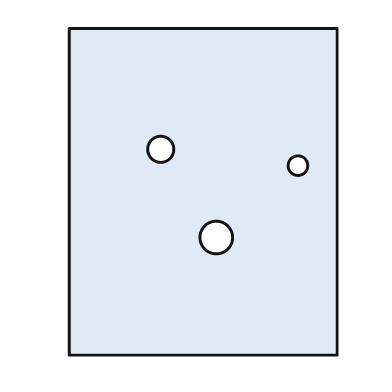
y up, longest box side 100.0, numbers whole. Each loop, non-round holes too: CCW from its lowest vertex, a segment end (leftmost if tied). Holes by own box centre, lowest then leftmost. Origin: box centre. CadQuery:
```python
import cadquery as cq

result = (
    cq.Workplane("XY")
    .moveTo(-41.0, -50.0)
    .lineTo(41.0, -50.0)
    .lineTo(41.0, 50.0)
    .lineTo(-41.0, 50.0)
    .close()
    .moveTo(4.0, -14.0)
    .circle(5.0)
    .moveTo(29.0, 8.0)
    .circle(3.0)
    .moveTo(-13.0, 13.0)
    .circle(4.0)
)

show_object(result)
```